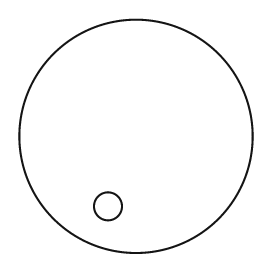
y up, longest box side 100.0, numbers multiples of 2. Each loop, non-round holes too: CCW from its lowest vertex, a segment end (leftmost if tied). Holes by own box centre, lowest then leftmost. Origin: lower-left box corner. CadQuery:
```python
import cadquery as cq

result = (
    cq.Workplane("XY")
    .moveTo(50.0, 50.0)
    .circle(50.0)
    .moveTo(38.0, 20.0)
    .circle(6.0)
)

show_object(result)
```